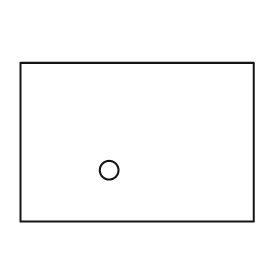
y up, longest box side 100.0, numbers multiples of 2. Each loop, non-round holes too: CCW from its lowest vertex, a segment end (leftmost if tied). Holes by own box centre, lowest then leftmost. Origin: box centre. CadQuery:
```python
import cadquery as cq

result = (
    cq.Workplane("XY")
    .moveTo(-50.0, -34.0)
    .lineTo(50.0, -34.0)
    .lineTo(50.0, 34.0)
    .lineTo(-50.0, 34.0)
    .close()
    .moveTo(-12.0, -12.0)
    .circle(4.0)
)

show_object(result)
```